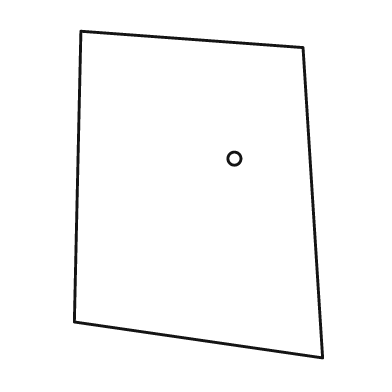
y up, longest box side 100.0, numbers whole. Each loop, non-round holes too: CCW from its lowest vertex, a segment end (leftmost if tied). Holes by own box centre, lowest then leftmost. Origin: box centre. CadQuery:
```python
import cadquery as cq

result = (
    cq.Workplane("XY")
    .moveTo(38.0, -50.0)
    .lineTo(32.0, 45.0)
    .lineTo(-36.0, 50.0)
    .lineTo(-38.0, -39.0)
    .close()
    .moveTo(11.0, 11.0)
    .circle(2.0)
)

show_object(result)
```